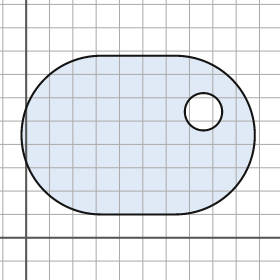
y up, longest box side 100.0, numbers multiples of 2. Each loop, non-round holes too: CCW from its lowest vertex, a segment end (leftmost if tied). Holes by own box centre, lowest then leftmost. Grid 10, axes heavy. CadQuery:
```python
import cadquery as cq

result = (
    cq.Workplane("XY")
    .moveTo(32.0, 10.0)
    .lineTo(64.0, 10.0)
    .threePointArc((98.0, 44.0), (64.0, 78.0))
    .lineTo(32.0, 78.0)
    .threePointArc((-2.0, 44.0), (32.0, 10.0))
    .close()
    .moveTo(76.0, 54.0)
    .circle(8.0)
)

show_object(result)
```